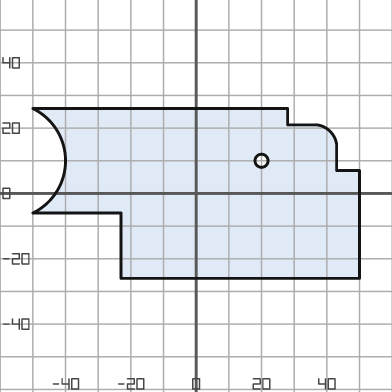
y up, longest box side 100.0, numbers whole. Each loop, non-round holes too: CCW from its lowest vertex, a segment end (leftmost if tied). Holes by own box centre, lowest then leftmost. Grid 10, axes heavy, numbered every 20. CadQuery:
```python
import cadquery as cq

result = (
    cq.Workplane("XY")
    .moveTo(-23.0, -26.0)
    .lineTo(50.0, -26.0)
    .lineTo(50.0, 7.0)
    .lineTo(43.0, 7.0)
    .lineTo(43.0, 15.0)
    .threePointArc((41.0, 19.0), (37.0, 21.0))
    .lineTo(28.0, 21.0)
    .lineTo(28.0, 26.0)
    .lineTo(-50.0, 26.0)
    .threePointArc((-40.0, 10.0), (-50.0, -6.0))
    .lineTo(-23.0, -6.0)
    .close()
    .moveTo(20.0, 10.0)
    .circle(2.0)
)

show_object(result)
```